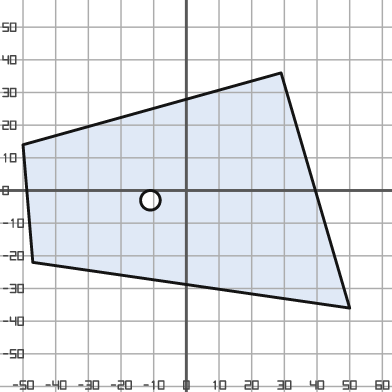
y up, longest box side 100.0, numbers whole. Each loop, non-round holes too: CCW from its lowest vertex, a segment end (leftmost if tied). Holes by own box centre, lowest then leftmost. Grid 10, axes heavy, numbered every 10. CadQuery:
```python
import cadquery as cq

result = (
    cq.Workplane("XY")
    .moveTo(50.0, -36.0)
    .lineTo(29.0, 36.0)
    .lineTo(-50.0, 14.0)
    .lineTo(-47.0, -22.0)
    .close()
    .moveTo(-11.0, -3.0)
    .circle(3.0)
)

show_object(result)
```